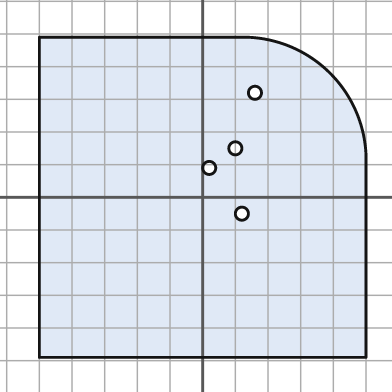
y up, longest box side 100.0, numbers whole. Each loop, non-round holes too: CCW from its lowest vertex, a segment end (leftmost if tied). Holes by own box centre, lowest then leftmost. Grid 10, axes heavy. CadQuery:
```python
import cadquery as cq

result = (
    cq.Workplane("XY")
    .moveTo(-50.0, -49.0)
    .lineTo(50.0, -49.0)
    .lineTo(50.0, 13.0)
    .threePointArc((39.0, 38.0), (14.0, 49.0))
    .lineTo(-50.0, 49.0)
    .close()
    .moveTo(12.0, -5.0)
    .circle(2.0)
    .moveTo(2.0, 9.0)
    .circle(2.0)
    .moveTo(10.0, 15.0)
    .circle(2.0)
    .moveTo(16.0, 32.0)
    .circle(2.0)
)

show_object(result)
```